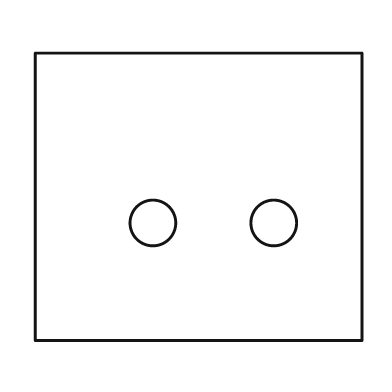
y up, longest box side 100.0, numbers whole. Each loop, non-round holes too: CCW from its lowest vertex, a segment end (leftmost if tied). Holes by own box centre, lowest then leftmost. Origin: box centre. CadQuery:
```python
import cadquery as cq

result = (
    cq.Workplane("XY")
    .moveTo(-50.0, -44.0)
    .lineTo(50.0, -44.0)
    .lineTo(50.0, 44.0)
    .lineTo(-50.0, 44.0)
    .close()
    .moveTo(-14.0, -8.0)
    .circle(7.0)
    .moveTo(23.0, -8.0)
    .circle(7.0)
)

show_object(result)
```